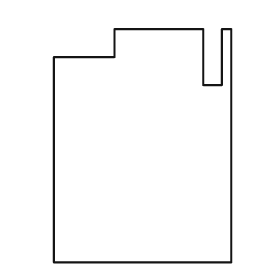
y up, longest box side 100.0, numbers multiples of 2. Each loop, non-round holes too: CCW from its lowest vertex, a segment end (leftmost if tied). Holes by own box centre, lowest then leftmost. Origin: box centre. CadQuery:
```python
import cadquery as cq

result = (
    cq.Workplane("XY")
    .moveTo(-38.0, -50.0)
    .lineTo(38.0, -50.0)
    .lineTo(38.0, 50.0)
    .lineTo(34.0, 50.0)
    .lineTo(34.0, 26.0)
    .lineTo(26.0, 26.0)
    .lineTo(26.0, 50.0)
    .lineTo(-12.0, 50.0)
    .lineTo(-12.0, 38.0)
    .lineTo(-38.0, 38.0)
    .close()
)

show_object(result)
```